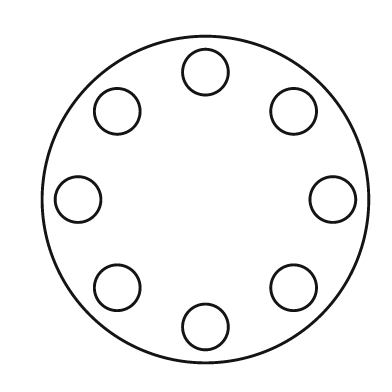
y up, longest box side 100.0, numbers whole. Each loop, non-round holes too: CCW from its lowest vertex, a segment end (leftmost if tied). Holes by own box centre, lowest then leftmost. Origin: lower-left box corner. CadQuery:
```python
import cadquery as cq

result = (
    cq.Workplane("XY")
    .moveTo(50.0, 50.0)
    .circle(50.0)
    .moveTo(50.0, 11.0)
    .circle(7.0)
    .moveTo(23.0, 23.0)
    .circle(7.0)
    .moveTo(77.0, 23.0)
    .circle(7.0)
    .moveTo(11.0, 50.0)
    .circle(7.0)
    .moveTo(89.0, 50.0)
    .circle(7.0)
    .moveTo(23.0, 77.0)
    .circle(7.0)
    .moveTo(77.0, 77.0)
    .circle(7.0)
    .moveTo(50.0, 89.0)
    .circle(7.0)
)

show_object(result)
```